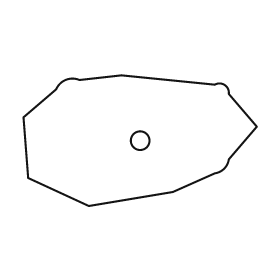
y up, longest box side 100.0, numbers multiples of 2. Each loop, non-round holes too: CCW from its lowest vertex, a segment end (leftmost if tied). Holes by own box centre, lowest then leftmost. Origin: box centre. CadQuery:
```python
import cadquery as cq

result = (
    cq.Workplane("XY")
    .moveTo(-22.0, -28.0)
    .lineTo(14.0, -22.0)
    .lineTo(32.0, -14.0)
    .threePointArc((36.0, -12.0), (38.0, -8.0))
    .lineTo(50.0, 6.0)
    .lineTo(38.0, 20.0)
    .threePointArc((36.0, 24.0), (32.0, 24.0))
    .lineTo(-8.0, 28.0)
    .lineTo(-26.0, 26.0)
    .threePointArc((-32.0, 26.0), (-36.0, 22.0))
    .lineTo(-50.0, 10.0)
    .lineTo(-48.0, -16.0)
    .close()
    .moveTo(0.0, 0.0)
    .circle(4.0)
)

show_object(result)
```